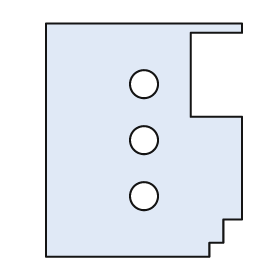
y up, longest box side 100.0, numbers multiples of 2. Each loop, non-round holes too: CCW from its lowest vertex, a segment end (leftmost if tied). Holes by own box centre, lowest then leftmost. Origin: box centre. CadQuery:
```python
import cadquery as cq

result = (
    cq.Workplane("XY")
    .moveTo(-42.0, -50.0)
    .lineTo(28.0, -50.0)
    .lineTo(28.0, -44.0)
    .lineTo(34.0, -44.0)
    .lineTo(34.0, -34.0)
    .lineTo(42.0, -34.0)
    .lineTo(42.0, 10.0)
    .lineTo(20.0, 10.0)
    .lineTo(20.0, 46.0)
    .lineTo(42.0, 46.0)
    .lineTo(42.0, 50.0)
    .lineTo(-42.0, 50.0)
    .close()
    .moveTo(0.0, -24.0)
    .circle(6.0)
    .moveTo(0.0, 0.0)
    .circle(6.0)
    .moveTo(0.0, 24.0)
    .circle(6.0)
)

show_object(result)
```